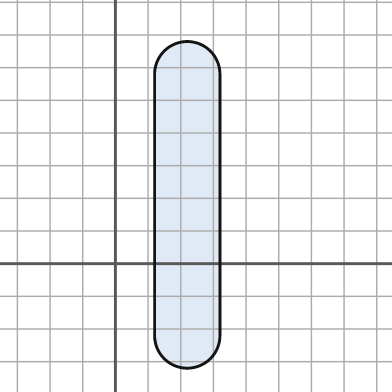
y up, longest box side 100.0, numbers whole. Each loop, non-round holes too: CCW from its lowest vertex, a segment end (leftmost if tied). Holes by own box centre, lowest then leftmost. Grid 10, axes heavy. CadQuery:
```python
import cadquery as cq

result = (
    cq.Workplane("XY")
    .moveTo(12.0, -22.0)
    .threePointArc((22.0, -32.0), (32.0, -22.0))
    .lineTo(32.0, 58.0)
    .threePointArc((22.0, 68.0), (12.0, 58.0))
    .close()
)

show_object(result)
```